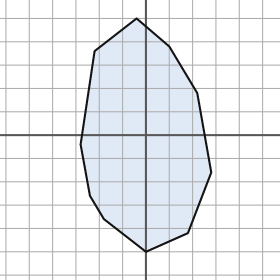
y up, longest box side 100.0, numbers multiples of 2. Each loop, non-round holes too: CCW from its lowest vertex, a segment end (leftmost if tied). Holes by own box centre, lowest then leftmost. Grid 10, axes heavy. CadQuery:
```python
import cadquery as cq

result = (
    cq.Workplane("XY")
    .moveTo(0.0, -50.0)
    .lineTo(18.0, -42.0)
    .lineTo(28.0, -16.0)
    .lineTo(22.0, 18.0)
    .lineTo(10.0, 38.0)
    .lineTo(-4.0, 50.0)
    .lineTo(-22.0, 36.0)
    .lineTo(-28.0, -4.0)
    .lineTo(-24.0, -26.0)
    .lineTo(-18.0, -36.0)
    .close()
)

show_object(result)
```